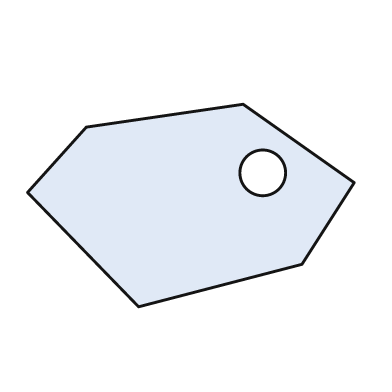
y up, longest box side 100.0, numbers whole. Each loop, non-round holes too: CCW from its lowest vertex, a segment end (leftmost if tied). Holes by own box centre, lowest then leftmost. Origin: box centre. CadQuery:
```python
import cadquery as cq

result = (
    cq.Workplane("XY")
    .moveTo(-16.0, -31.0)
    .lineTo(34.0, -18.0)
    .lineTo(50.0, 7.0)
    .lineTo(16.0, 31.0)
    .lineTo(-32.0, 24.0)
    .lineTo(-50.0, 4.0)
    .close()
    .moveTo(22.0, 10.0)
    .circle(7.0)
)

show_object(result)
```